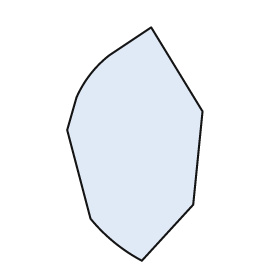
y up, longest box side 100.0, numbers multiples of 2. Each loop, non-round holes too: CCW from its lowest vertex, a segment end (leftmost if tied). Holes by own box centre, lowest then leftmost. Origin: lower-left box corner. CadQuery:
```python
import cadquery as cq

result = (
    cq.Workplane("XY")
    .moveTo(32.0, 0.0)
    .lineTo(54.0, 24.0)
    .lineTo(58.0, 64.0)
    .lineTo(36.0, 100.0)
    .lineTo(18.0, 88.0)
    .threePointArc((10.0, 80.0), (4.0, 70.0))
    .lineTo(0.0, 56.0)
    .lineTo(10.0, 18.0)
    .threePointArc((20.0, 8.0), (32.0, 0.0))
    .close()
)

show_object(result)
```